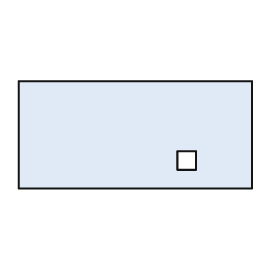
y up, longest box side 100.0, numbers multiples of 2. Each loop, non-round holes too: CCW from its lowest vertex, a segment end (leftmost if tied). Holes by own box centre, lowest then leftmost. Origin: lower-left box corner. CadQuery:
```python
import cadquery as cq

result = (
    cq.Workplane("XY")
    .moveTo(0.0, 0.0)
    .lineTo(100.0, 0.0)
    .lineTo(100.0, 46.0)
    .lineTo(0.0, 46.0)
    .close()
    .moveTo(68.0, 8.0)
    .lineTo(76.0, 8.0)
    .lineTo(76.0, 16.0)
    .lineTo(68.0, 16.0)
    .close()
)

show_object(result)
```